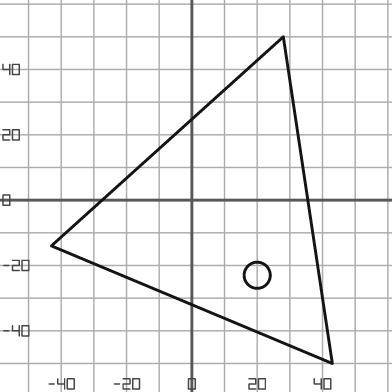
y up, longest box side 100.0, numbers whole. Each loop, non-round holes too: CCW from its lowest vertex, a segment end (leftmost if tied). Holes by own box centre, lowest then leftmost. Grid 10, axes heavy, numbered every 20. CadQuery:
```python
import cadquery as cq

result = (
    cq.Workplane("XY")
    .moveTo(43.0, -50.0)
    .lineTo(28.0, 50.0)
    .lineTo(-43.0, -14.0)
    .close()
    .moveTo(20.0, -23.0)
    .circle(4.0)
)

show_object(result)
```